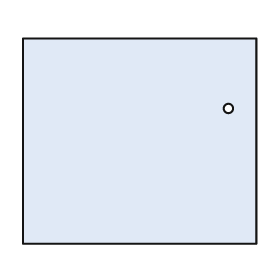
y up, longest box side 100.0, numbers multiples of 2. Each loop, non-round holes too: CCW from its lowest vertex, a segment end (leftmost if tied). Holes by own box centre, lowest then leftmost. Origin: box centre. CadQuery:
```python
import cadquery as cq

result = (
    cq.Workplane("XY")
    .moveTo(-50.0, -44.0)
    .lineTo(50.0, -44.0)
    .lineTo(50.0, 44.0)
    .lineTo(-50.0, 44.0)
    .close()
    .moveTo(38.0, 14.0)
    .circle(2.0)
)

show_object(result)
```